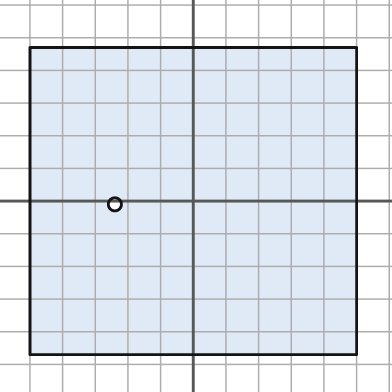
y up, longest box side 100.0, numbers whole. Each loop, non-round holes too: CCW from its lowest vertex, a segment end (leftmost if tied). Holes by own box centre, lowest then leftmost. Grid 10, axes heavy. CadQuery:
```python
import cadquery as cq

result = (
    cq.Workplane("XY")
    .moveTo(-50.0, -47.0)
    .lineTo(50.0, -47.0)
    .lineTo(50.0, 47.0)
    .lineTo(-50.0, 47.0)
    .close()
    .moveTo(-24.0, -1.0)
    .circle(2.0)
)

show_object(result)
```